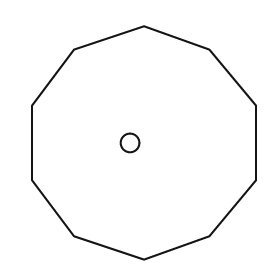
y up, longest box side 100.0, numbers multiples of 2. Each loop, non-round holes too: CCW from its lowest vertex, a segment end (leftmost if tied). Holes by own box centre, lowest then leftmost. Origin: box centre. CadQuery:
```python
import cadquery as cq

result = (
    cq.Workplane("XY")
    .moveTo(0.0, -50.0)
    .lineTo(28.0, -40.0)
    .lineTo(48.0, -16.0)
    .lineTo(48.0, 16.0)
    .lineTo(28.0, 40.0)
    .lineTo(0.0, 50.0)
    .lineTo(-30.0, 40.0)
    .lineTo(-48.0, 16.0)
    .lineTo(-48.0, -16.0)
    .lineTo(-30.0, -40.0)
    .close()
    .moveTo(-6.0, 0.0)
    .circle(4.0)
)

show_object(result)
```